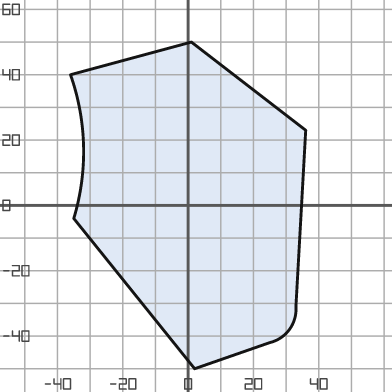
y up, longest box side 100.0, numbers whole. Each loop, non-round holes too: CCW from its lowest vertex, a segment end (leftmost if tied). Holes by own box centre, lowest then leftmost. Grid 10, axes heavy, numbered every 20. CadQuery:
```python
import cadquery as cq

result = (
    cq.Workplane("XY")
    .moveTo(2.0, -50.0)
    .lineTo(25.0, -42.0)
    .threePointArc((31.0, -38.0), (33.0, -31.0))
    .lineTo(36.0, 23.0)
    .lineTo(1.0, 50.0)
    .lineTo(-36.0, 40.0)
    .threePointArc((-32.0, 18.0), (-35.0, -4.0))
    .close()
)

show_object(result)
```